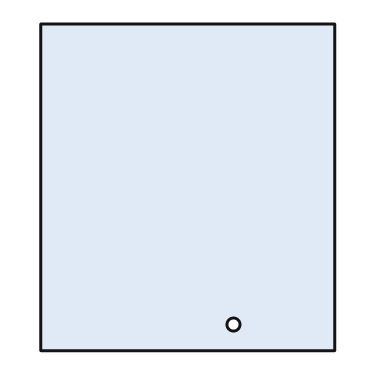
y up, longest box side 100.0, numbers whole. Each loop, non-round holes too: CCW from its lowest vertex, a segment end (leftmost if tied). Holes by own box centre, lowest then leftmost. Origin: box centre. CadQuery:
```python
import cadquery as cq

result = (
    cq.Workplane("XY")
    .moveTo(-45.0, -50.0)
    .lineTo(45.0, -50.0)
    .lineTo(45.0, 50.0)
    .lineTo(-45.0, 50.0)
    .close()
    .moveTo(14.0, -42.0)
    .circle(2.0)
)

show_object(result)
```